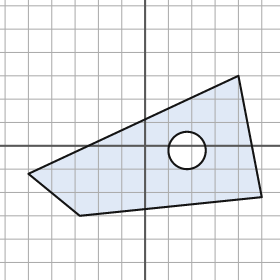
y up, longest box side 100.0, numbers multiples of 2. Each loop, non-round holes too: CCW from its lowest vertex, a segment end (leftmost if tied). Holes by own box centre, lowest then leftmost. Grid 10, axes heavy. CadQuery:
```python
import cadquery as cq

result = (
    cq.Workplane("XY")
    .moveTo(-28.0, -30.0)
    .lineTo(50.0, -22.0)
    .lineTo(40.0, 30.0)
    .lineTo(-50.0, -12.0)
    .close()
    .moveTo(18.0, -2.0)
    .circle(8.0)
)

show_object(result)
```